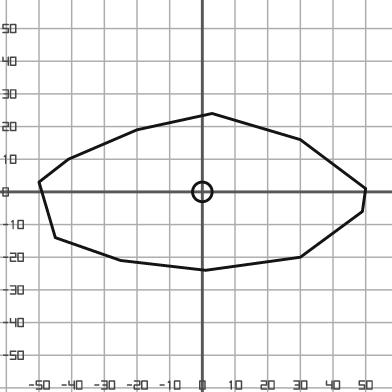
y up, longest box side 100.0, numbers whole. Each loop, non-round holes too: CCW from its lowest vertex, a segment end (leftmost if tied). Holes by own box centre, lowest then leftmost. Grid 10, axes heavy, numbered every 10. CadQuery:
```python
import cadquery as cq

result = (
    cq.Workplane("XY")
    .moveTo(1.0, -24.0)
    .lineTo(30.0, -20.0)
    .lineTo(49.0, -6.0)
    .lineTo(50.0, 1.0)
    .lineTo(30.0, 16.0)
    .lineTo(3.0, 24.0)
    .lineTo(-20.0, 19.0)
    .lineTo(-41.0, 10.0)
    .lineTo(-50.0, 3.0)
    .lineTo(-45.0, -14.0)
    .lineTo(-25.0, -21.0)
    .close()
    .moveTo(0.0, 0.0)
    .circle(3.0)
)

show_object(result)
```